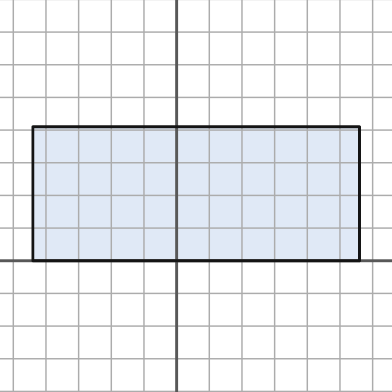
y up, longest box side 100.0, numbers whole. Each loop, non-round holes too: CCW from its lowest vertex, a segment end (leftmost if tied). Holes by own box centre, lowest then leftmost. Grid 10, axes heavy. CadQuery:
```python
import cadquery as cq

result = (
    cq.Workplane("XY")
    .moveTo(-44.0, 0.0)
    .lineTo(56.0, 0.0)
    .lineTo(56.0, 41.0)
    .lineTo(-44.0, 41.0)
    .close()
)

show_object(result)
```